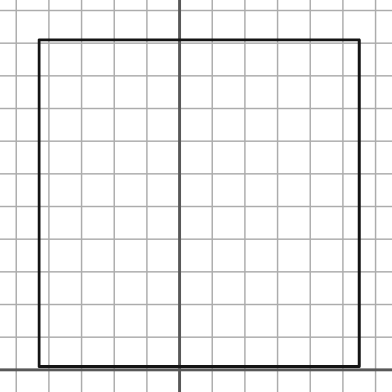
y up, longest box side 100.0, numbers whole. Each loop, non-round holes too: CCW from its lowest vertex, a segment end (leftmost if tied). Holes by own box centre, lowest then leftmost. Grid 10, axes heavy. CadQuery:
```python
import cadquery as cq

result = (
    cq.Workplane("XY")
    .moveTo(-43.0, 1.0)
    .lineTo(55.0, 1.0)
    .lineTo(55.0, 101.0)
    .lineTo(-43.0, 101.0)
    .close()
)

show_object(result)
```